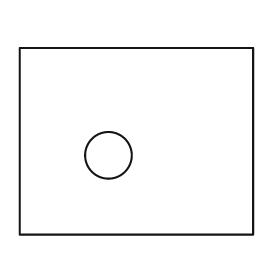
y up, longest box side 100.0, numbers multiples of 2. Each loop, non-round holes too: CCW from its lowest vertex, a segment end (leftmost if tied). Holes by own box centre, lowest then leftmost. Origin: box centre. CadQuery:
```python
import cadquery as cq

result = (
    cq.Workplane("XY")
    .moveTo(-50.0, -40.0)
    .lineTo(50.0, -40.0)
    .lineTo(50.0, 40.0)
    .lineTo(-50.0, 40.0)
    .close()
    .moveTo(-12.0, -6.0)
    .circle(10.0)
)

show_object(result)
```